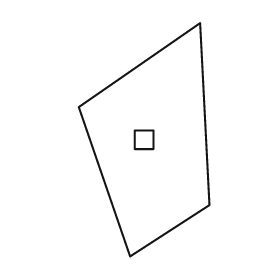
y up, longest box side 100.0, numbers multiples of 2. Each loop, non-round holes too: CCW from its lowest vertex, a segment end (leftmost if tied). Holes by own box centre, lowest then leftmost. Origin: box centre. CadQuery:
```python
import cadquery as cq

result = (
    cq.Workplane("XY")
    .moveTo(-6.0, -50.0)
    .lineTo(28.0, -28.0)
    .lineTo(24.0, 50.0)
    .lineTo(-28.0, 14.0)
    .close()
    .moveTo(-4.0, -4.0)
    .lineTo(4.0, -4.0)
    .lineTo(4.0, 4.0)
    .lineTo(-4.0, 4.0)
    .close()
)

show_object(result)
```